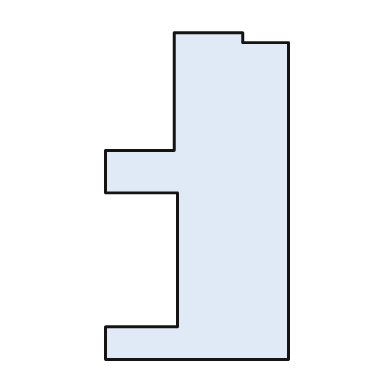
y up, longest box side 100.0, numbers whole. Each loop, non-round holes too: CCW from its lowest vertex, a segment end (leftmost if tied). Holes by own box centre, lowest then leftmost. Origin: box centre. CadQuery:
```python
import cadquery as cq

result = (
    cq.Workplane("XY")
    .moveTo(-28.0, -50.0)
    .lineTo(28.0, -50.0)
    .lineTo(28.0, 47.0)
    .lineTo(14.0, 47.0)
    .lineTo(14.0, 50.0)
    .lineTo(-7.0, 50.0)
    .lineTo(-7.0, 14.0)
    .lineTo(-28.0, 14.0)
    .lineTo(-28.0, 1.0)
    .lineTo(-6.0, 1.0)
    .lineTo(-6.0, -40.0)
    .lineTo(-28.0, -40.0)
    .close()
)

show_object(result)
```